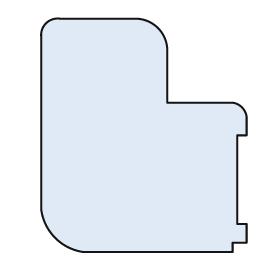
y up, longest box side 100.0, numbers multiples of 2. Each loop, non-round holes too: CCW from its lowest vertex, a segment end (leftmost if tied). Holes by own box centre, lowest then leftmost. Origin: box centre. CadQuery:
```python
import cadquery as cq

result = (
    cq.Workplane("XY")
    .moveTo(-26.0, -50.0)
    .lineTo(38.0, -50.0)
    .lineTo(38.0, -46.0)
    .lineTo(44.0, -46.0)
    .lineTo(44.0, -38.0)
    .lineTo(40.0, -38.0)
    .lineTo(40.0, 0.0)
    .lineTo(44.0, 0.0)
    .lineTo(44.0, 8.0)
    .threePointArc((42.0, 12.0), (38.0, 14.0))
    .lineTo(10.0, 14.0)
    .lineTo(10.0, 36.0)
    .threePointArc((6.0, 46.0), (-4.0, 50.0))
    .lineTo(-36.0, 50.0)
    .threePointArc((-42.0, 48.0), (-44.0, 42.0))
    .lineTo(-44.0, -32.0)
    .threePointArc((-38.0, -44.0), (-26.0, -50.0))
    .close()
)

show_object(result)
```